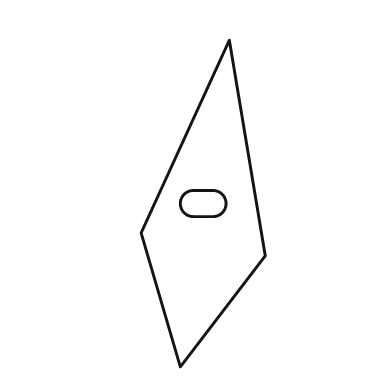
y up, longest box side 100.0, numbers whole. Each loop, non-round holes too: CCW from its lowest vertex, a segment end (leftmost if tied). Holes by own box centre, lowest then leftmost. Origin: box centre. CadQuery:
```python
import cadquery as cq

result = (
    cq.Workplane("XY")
    .moveTo(-7.0, -50.0)
    .lineTo(19.0, -16.0)
    .lineTo(8.0, 50.0)
    .lineTo(-19.0, -9.0)
    .close()
    .moveTo(-3.0, -4.0)
    .lineTo(3.0, -4.0)
    .threePointArc((7.0, 0.0), (3.0, 4.0))
    .lineTo(-3.0, 4.0)
    .threePointArc((-7.0, 0.0), (-3.0, -4.0))
    .close()
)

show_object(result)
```